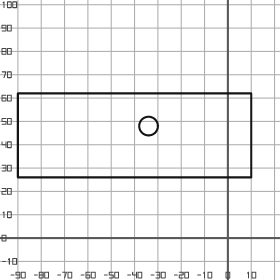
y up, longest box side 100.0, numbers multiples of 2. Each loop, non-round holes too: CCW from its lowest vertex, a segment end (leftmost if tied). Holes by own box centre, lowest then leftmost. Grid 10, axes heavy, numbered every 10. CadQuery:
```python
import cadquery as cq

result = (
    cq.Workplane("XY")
    .moveTo(-90.0, 26.0)
    .lineTo(10.0, 26.0)
    .lineTo(10.0, 62.0)
    .lineTo(-90.0, 62.0)
    .close()
    .moveTo(-34.0, 48.0)
    .circle(4.0)
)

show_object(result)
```